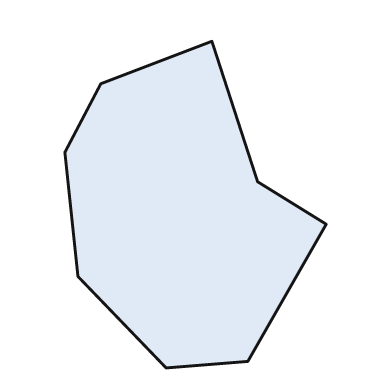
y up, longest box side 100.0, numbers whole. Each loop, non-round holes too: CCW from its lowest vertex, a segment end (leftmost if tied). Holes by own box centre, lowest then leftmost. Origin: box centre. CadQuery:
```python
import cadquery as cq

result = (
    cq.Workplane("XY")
    .moveTo(-9.0, -50.0)
    .lineTo(16.0, -48.0)
    .lineTo(40.0, -6.0)
    .lineTo(19.0, 7.0)
    .lineTo(5.0, 50.0)
    .lineTo(-29.0, 37.0)
    .lineTo(-40.0, 16.0)
    .lineTo(-36.0, -22.0)
    .close()
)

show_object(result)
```